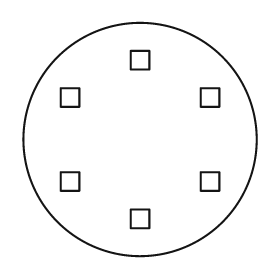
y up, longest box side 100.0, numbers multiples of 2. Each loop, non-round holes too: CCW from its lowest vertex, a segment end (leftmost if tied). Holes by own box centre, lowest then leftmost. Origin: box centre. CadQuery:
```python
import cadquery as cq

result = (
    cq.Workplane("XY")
    .moveTo(0.0, 0.0)
    .circle(50.0)
    .moveTo(-4.0, -38.0)
    .lineTo(4.0, -38.0)
    .lineTo(4.0, -30.0)
    .lineTo(-4.0, -30.0)
    .close()
    .moveTo(-34.0, -22.0)
    .lineTo(-26.0, -22.0)
    .lineTo(-26.0, -14.0)
    .lineTo(-34.0, -14.0)
    .close()
    .moveTo(26.0, -22.0)
    .lineTo(34.0, -22.0)
    .lineTo(34.0, -14.0)
    .lineTo(26.0, -14.0)
    .close()
    .moveTo(-34.0, 14.0)
    .lineTo(-26.0, 14.0)
    .lineTo(-26.0, 22.0)
    .lineTo(-34.0, 22.0)
    .close()
    .moveTo(26.0, 14.0)
    .lineTo(34.0, 14.0)
    .lineTo(34.0, 22.0)
    .lineTo(26.0, 22.0)
    .close()
    .moveTo(-4.0, 30.0)
    .lineTo(4.0, 30.0)
    .lineTo(4.0, 38.0)
    .lineTo(-4.0, 38.0)
    .close()
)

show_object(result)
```